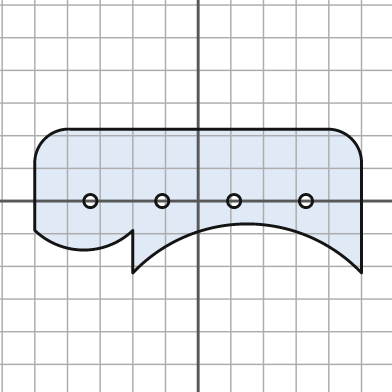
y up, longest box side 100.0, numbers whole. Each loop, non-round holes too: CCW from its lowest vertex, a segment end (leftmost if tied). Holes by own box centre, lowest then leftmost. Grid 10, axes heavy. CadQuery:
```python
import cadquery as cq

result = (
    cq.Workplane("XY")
    .moveTo(-20.0, -22.0)
    .threePointArc((15.0, -7.0), (50.0, -22.0))
    .lineTo(50.0, 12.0)
    .threePointArc((47.0, 19.0), (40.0, 22.0))
    .lineTo(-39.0, 22.0)
    .threePointArc((-47.0, 19.0), (-50.0, 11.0))
    .lineTo(-50.0, -9.0)
    .threePointArc((-35.0, -15.0), (-20.0, -9.0))
    .close()
    .moveTo(-33.0, 0.0)
    .circle(2.0)
    .moveTo(-11.0, 0.0)
    .circle(2.0)
    .moveTo(11.0, 0.0)
    .circle(2.0)
    .moveTo(33.0, 0.0)
    .circle(2.0)
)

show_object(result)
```